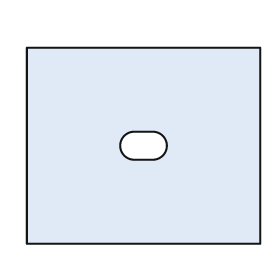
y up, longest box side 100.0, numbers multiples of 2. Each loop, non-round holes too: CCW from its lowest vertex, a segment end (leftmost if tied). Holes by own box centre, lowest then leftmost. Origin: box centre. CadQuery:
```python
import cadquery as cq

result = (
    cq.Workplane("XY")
    .moveTo(-50.0, -42.0)
    .lineTo(50.0, -42.0)
    .lineTo(50.0, 42.0)
    .lineTo(-50.0, 42.0)
    .close()
    .moveTo(-4.0, -6.0)
    .lineTo(4.0, -6.0)
    .threePointArc((10.0, 0.0), (4.0, 6.0))
    .lineTo(-4.0, 6.0)
    .threePointArc((-10.0, 0.0), (-4.0, -6.0))
    .close()
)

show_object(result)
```